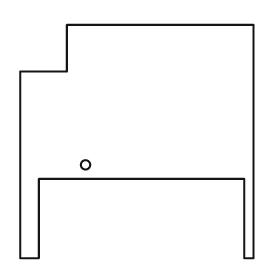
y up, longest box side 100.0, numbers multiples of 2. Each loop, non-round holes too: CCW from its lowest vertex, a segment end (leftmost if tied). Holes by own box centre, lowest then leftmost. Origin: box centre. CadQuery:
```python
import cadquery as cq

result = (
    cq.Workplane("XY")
    .moveTo(-50.0, -50.0)
    .lineTo(-42.0, -50.0)
    .lineTo(-42.0, -16.0)
    .lineTo(46.0, -16.0)
    .lineTo(46.0, -50.0)
    .lineTo(50.0, -50.0)
    .lineTo(50.0, 50.0)
    .lineTo(-30.0, 50.0)
    .lineTo(-30.0, 30.0)
    .lineTo(-50.0, 30.0)
    .close()
    .moveTo(-22.0, -10.0)
    .circle(2.0)
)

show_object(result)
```